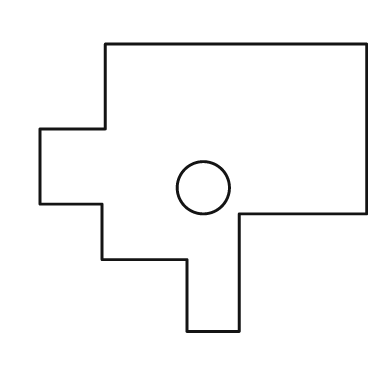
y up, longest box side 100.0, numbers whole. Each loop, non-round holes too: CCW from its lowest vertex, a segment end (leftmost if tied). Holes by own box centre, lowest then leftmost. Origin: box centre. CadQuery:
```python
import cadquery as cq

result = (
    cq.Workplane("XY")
    .moveTo(-5.0, -44.0)
    .lineTo(11.0, -44.0)
    .lineTo(11.0, -8.0)
    .lineTo(50.0, -8.0)
    .lineTo(50.0, 44.0)
    .lineTo(-30.0, 44.0)
    .lineTo(-30.0, 18.0)
    .lineTo(-50.0, 18.0)
    .lineTo(-50.0, -5.0)
    .lineTo(-31.0, -5.0)
    .lineTo(-31.0, -22.0)
    .lineTo(-5.0, -22.0)
    .close()
    .moveTo(0.0, 0.0)
    .circle(8.0)
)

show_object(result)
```